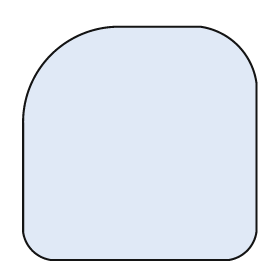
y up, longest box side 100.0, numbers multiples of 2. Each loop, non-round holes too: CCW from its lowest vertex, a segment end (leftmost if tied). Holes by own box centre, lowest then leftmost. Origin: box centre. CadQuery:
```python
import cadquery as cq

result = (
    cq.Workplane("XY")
    .moveTo(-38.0, -50.0)
    .lineTo(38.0, -50.0)
    .threePointArc((46.0, -46.0), (50.0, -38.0))
    .lineTo(50.0, 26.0)
    .threePointArc((42.0, 42.0), (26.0, 50.0))
    .lineTo(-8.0, 50.0)
    .threePointArc((-38.0, 38.0), (-50.0, 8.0))
    .lineTo(-50.0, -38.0)
    .threePointArc((-46.0, -46.0), (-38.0, -50.0))
    .close()
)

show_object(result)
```